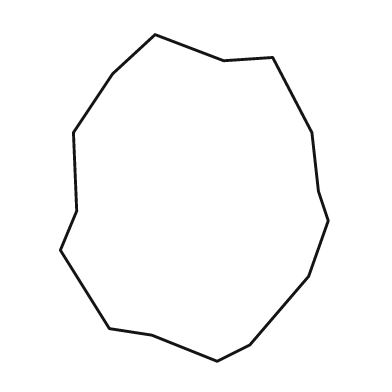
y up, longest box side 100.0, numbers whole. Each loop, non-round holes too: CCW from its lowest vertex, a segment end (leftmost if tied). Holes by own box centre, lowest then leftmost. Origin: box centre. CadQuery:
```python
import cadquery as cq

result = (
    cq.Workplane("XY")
    .moveTo(7.0, -50.0)
    .lineTo(17.0, -45.0)
    .lineTo(35.0, -24.0)
    .lineTo(41.0, -7.0)
    .lineTo(38.0, 2.0)
    .lineTo(36.0, 20.0)
    .lineTo(24.0, 43.0)
    .lineTo(9.0, 42.0)
    .lineTo(-12.0, 50.0)
    .lineTo(-25.0, 38.0)
    .lineTo(-37.0, 20.0)
    .lineTo(-36.0, -4.0)
    .lineTo(-41.0, -16.0)
    .lineTo(-26.0, -40.0)
    .lineTo(-13.0, -42.0)
    .close()
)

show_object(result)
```